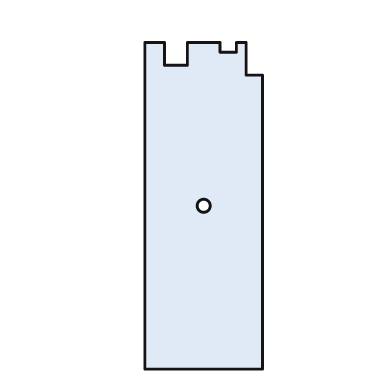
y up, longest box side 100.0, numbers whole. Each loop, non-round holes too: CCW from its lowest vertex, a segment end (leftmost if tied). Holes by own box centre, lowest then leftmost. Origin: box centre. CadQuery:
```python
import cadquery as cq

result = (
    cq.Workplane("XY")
    .moveTo(-18.0, -50.0)
    .lineTo(18.0, -50.0)
    .lineTo(18.0, 40.0)
    .lineTo(13.0, 40.0)
    .lineTo(13.0, 50.0)
    .lineTo(10.0, 50.0)
    .lineTo(10.0, 47.0)
    .lineTo(5.0, 47.0)
    .lineTo(5.0, 50.0)
    .lineTo(-5.0, 50.0)
    .lineTo(-5.0, 43.0)
    .lineTo(-12.0, 43.0)
    .lineTo(-12.0, 50.0)
    .lineTo(-18.0, 50.0)
    .close()
    .moveTo(0.0, 0.0)
    .circle(2.0)
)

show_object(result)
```